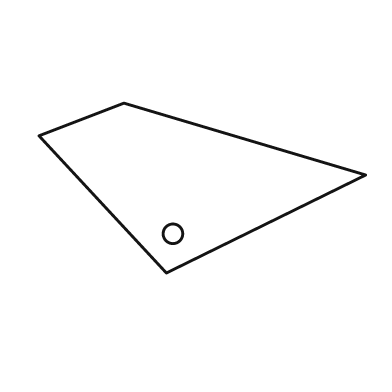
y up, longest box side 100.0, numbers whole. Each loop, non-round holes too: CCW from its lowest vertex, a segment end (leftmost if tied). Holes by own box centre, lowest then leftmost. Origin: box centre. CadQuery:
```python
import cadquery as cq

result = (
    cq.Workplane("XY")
    .moveTo(-11.0, -26.0)
    .lineTo(50.0, 4.0)
    .lineTo(-24.0, 26.0)
    .lineTo(-50.0, 16.0)
    .close()
    .moveTo(-9.0, -14.0)
    .circle(3.0)
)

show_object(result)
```